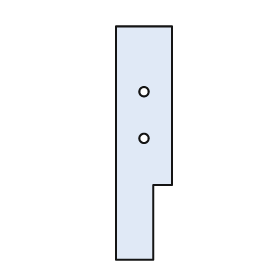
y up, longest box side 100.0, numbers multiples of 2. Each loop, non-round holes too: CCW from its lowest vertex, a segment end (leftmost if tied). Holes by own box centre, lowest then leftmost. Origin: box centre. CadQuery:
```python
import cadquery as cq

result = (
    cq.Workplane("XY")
    .moveTo(-12.0, -50.0)
    .lineTo(4.0, -50.0)
    .lineTo(4.0, -18.0)
    .lineTo(12.0, -18.0)
    .lineTo(12.0, 50.0)
    .lineTo(-12.0, 50.0)
    .close()
    .moveTo(0.0, 2.0)
    .circle(2.0)
    .moveTo(0.0, 22.0)
    .circle(2.0)
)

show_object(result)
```